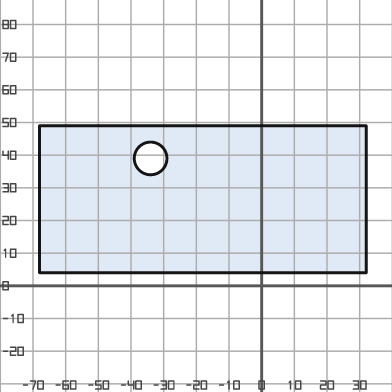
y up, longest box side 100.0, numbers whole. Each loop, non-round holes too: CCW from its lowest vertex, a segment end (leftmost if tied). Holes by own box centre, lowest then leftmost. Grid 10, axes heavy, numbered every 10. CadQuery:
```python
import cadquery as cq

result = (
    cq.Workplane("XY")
    .moveTo(-68.0, 4.0)
    .lineTo(32.0, 4.0)
    .lineTo(32.0, 49.0)
    .lineTo(-68.0, 49.0)
    .close()
    .moveTo(-34.0, 39.0)
    .circle(5.0)
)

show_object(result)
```